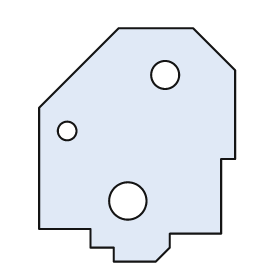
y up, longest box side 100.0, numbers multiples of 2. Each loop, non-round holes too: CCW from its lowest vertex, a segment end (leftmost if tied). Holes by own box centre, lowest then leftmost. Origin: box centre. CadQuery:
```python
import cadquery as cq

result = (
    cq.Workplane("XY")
    .moveTo(-10.0, -50.0)
    .lineTo(8.0, -50.0)
    .lineTo(14.0, -44.0)
    .lineTo(14.0, -38.0)
    .lineTo(36.0, -38.0)
    .lineTo(36.0, -6.0)
    .lineTo(42.0, -6.0)
    .lineTo(42.0, 32.0)
    .lineTo(24.0, 50.0)
    .lineTo(-8.0, 50.0)
    .lineTo(-42.0, 16.0)
    .lineTo(-42.0, -36.0)
    .lineTo(-20.0, -36.0)
    .lineTo(-20.0, -44.0)
    .lineTo(-10.0, -44.0)
    .close()
    .moveTo(-4.0, -24.0)
    .circle(8.0)
    .moveTo(-30.0, 6.0)
    .circle(4.0)
    .moveTo(12.0, 30.0)
    .circle(6.0)
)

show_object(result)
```